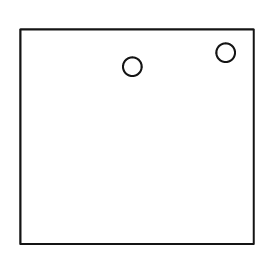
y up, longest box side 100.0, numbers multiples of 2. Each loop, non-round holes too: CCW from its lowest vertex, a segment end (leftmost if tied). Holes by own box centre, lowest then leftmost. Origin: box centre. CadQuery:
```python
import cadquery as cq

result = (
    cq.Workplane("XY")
    .moveTo(-50.0, -46.0)
    .lineTo(50.0, -46.0)
    .lineTo(50.0, 46.0)
    .lineTo(-50.0, 46.0)
    .close()
    .moveTo(-2.0, 30.0)
    .circle(4.0)
    .moveTo(38.0, 36.0)
    .circle(4.0)
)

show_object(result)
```